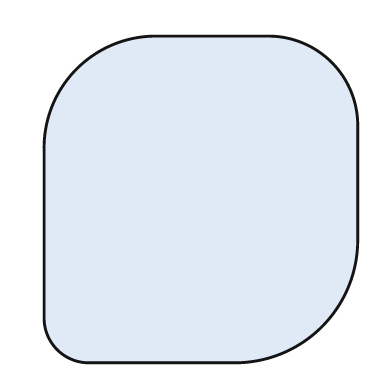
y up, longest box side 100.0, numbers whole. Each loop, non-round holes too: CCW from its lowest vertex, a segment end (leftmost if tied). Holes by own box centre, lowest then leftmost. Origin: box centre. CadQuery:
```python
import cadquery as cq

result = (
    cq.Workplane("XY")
    .moveTo(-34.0, -50.0)
    .lineTo(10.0, -50.0)
    .threePointArc((37.0, -39.0), (48.0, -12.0))
    .lineTo(48.0, 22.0)
    .threePointArc((40.0, 42.0), (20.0, 50.0))
    .lineTo(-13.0, 50.0)
    .threePointArc((-38.0, 40.0), (-48.0, 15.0))
    .lineTo(-48.0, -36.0)
    .threePointArc((-44.0, -46.0), (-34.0, -50.0))
    .close()
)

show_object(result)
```